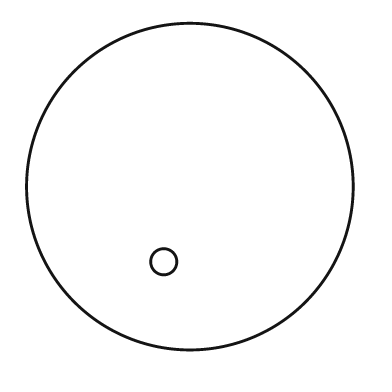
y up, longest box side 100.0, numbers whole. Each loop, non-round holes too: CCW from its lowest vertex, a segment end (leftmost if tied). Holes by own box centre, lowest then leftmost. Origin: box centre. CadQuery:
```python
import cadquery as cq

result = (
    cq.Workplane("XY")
    .moveTo(0.0, 0.0)
    .circle(50.0)
    .moveTo(-8.0, -23.0)
    .circle(4.0)
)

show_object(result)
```